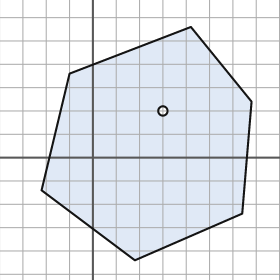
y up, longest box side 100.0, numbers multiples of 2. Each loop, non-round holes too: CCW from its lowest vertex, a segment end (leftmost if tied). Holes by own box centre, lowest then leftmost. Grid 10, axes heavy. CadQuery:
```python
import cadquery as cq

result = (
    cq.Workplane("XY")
    .moveTo(18.0, -44.0)
    .lineTo(64.0, -24.0)
    .lineTo(68.0, 24.0)
    .lineTo(42.0, 56.0)
    .lineTo(-10.0, 36.0)
    .lineTo(-22.0, -14.0)
    .close()
    .moveTo(30.0, 20.0)
    .circle(2.0)
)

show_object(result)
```